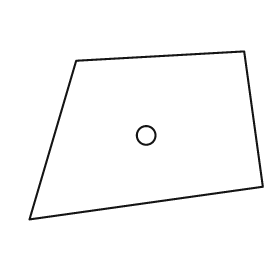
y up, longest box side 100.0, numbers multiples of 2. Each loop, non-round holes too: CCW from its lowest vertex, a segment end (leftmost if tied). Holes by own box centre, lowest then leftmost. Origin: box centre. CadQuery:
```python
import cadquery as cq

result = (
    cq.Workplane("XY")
    .moveTo(-50.0, -36.0)
    .lineTo(50.0, -22.0)
    .lineTo(42.0, 36.0)
    .lineTo(-30.0, 32.0)
    .close()
    .moveTo(0.0, 0.0)
    .circle(4.0)
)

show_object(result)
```